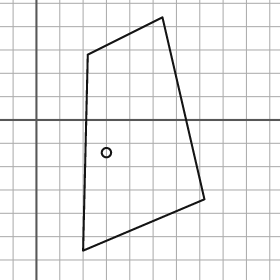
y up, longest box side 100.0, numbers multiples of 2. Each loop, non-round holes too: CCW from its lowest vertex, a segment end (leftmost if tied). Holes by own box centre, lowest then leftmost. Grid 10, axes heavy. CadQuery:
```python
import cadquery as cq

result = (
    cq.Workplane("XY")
    .moveTo(20.0, -56.0)
    .lineTo(72.0, -34.0)
    .lineTo(54.0, 44.0)
    .lineTo(22.0, 28.0)
    .close()
    .moveTo(30.0, -14.0)
    .circle(2.0)
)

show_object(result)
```